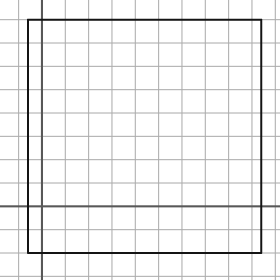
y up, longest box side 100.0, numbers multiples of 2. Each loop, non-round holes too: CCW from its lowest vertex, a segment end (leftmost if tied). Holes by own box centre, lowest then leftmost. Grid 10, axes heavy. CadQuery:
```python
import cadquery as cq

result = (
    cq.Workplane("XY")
    .moveTo(-6.0, -20.0)
    .lineTo(94.0, -20.0)
    .lineTo(94.0, 80.0)
    .lineTo(-6.0, 80.0)
    .close()
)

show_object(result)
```